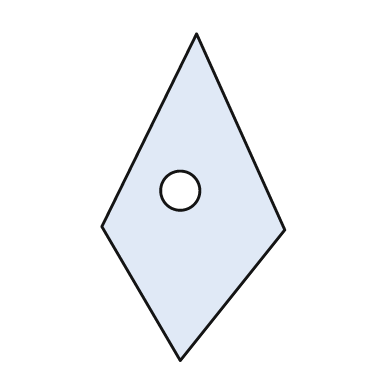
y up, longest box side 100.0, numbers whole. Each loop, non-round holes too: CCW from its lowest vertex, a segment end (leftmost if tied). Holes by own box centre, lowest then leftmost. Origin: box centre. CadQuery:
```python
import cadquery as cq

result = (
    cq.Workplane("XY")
    .moveTo(-4.0, -50.0)
    .lineTo(28.0, -10.0)
    .lineTo(1.0, 50.0)
    .lineTo(-28.0, -9.0)
    .close()
    .moveTo(-4.0, 2.0)
    .circle(6.0)
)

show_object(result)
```